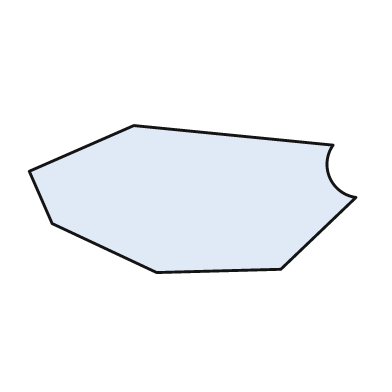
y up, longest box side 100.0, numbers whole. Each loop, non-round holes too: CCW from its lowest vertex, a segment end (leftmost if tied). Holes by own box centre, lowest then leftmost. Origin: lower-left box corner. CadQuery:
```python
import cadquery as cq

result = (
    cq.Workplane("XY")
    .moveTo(39.0, 0.0)
    .lineTo(77.0, 1.0)
    .lineTo(100.0, 23.0)
    .threePointArc((92.0, 29.0), (93.0, 39.0))
    .lineTo(32.0, 45.0)
    .lineTo(0.0, 31.0)
    .lineTo(7.0, 15.0)
    .close()
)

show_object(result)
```